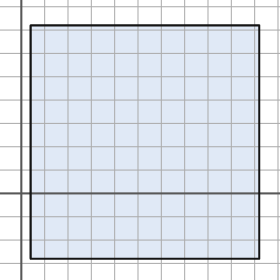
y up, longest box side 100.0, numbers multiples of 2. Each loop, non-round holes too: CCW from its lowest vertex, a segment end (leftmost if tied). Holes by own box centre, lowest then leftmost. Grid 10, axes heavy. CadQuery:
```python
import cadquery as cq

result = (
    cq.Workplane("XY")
    .moveTo(4.0, -28.0)
    .lineTo(102.0, -28.0)
    .lineTo(102.0, 72.0)
    .lineTo(4.0, 72.0)
    .close()
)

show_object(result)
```